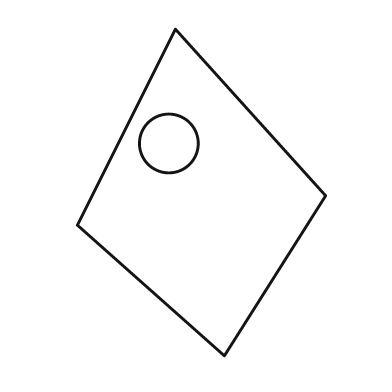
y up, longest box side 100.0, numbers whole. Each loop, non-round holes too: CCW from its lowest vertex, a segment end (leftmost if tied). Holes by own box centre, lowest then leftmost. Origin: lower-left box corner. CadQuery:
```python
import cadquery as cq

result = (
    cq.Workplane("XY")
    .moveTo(45.0, 0.0)
    .lineTo(76.0, 49.0)
    .lineTo(30.0, 100.0)
    .lineTo(0.0, 40.0)
    .close()
    .moveTo(28.0, 65.0)
    .circle(9.0)
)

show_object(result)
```